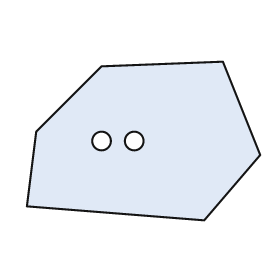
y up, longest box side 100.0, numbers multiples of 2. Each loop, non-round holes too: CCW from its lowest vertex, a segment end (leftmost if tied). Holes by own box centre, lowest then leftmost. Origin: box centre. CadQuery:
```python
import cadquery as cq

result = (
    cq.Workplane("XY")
    .moveTo(26.0, -34.0)
    .lineTo(50.0, -6.0)
    .lineTo(34.0, 34.0)
    .lineTo(-18.0, 32.0)
    .lineTo(-46.0, 4.0)
    .lineTo(-50.0, -28.0)
    .close()
    .moveTo(-18.0, 0.0)
    .circle(4.0)
    .moveTo(-4.0, 0.0)
    .circle(4.0)
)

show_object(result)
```